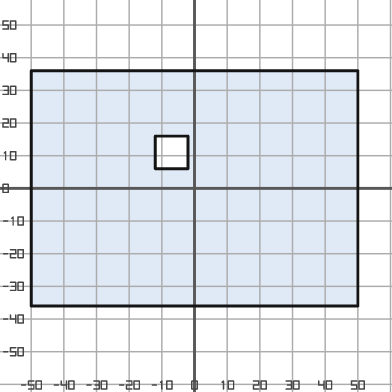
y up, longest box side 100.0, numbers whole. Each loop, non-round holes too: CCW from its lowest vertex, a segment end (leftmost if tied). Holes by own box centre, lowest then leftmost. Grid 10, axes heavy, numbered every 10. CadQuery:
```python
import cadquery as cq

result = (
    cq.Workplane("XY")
    .moveTo(-50.0, -36.0)
    .lineTo(50.0, -36.0)
    .lineTo(50.0, 36.0)
    .lineTo(-50.0, 36.0)
    .close()
    .moveTo(-12.0, 6.0)
    .lineTo(-2.0, 6.0)
    .lineTo(-2.0, 16.0)
    .lineTo(-12.0, 16.0)
    .close()
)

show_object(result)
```